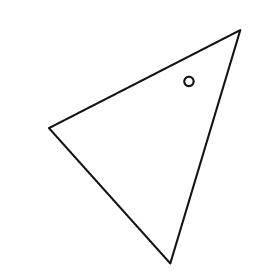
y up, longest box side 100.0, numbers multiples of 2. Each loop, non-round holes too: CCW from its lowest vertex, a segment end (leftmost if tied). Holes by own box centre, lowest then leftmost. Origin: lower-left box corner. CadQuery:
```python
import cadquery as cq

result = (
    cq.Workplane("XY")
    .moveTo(52.0, 0.0)
    .lineTo(82.0, 100.0)
    .lineTo(0.0, 58.0)
    .close()
    .moveTo(60.0, 78.0)
    .circle(2.0)
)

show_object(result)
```